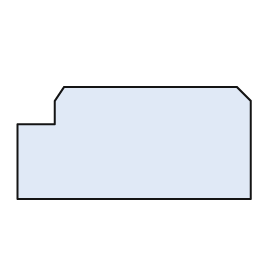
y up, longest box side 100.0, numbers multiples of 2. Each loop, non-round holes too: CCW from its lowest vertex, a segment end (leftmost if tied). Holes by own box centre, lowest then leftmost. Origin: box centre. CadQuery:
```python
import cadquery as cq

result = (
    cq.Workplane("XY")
    .moveTo(-50.0, -24.0)
    .lineTo(50.0, -24.0)
    .lineTo(50.0, 18.0)
    .lineTo(44.0, 24.0)
    .lineTo(-30.0, 24.0)
    .lineTo(-34.0, 18.0)
    .lineTo(-34.0, 8.0)
    .lineTo(-50.0, 8.0)
    .close()
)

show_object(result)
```